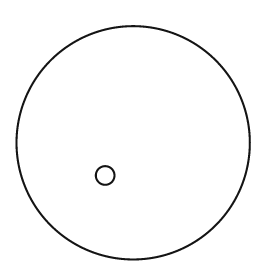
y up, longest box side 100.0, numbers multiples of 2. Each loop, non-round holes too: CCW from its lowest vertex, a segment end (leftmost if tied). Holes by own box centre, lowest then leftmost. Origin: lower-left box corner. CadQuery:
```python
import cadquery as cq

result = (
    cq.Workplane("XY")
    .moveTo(50.0, 50.0)
    .circle(50.0)
    .moveTo(38.0, 36.0)
    .circle(4.0)
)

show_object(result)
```